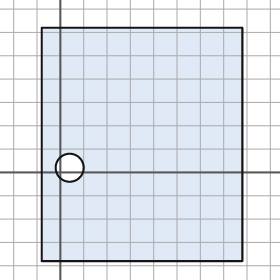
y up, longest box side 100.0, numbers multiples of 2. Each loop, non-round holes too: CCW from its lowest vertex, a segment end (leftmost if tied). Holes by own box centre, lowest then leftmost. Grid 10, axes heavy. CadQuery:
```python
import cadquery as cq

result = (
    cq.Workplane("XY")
    .moveTo(-8.0, -38.0)
    .lineTo(78.0, -38.0)
    .lineTo(78.0, 62.0)
    .lineTo(-8.0, 62.0)
    .close()
    .moveTo(4.0, 2.0)
    .circle(6.0)
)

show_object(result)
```